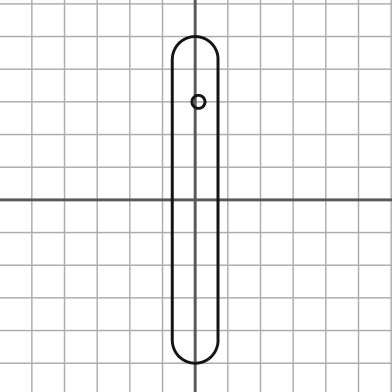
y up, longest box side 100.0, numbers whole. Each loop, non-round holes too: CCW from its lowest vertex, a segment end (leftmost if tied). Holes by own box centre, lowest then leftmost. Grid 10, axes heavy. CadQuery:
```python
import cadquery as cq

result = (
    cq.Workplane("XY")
    .moveTo(-7.0, -43.0)
    .threePointArc((0.0, -50.0), (7.0, -43.0))
    .lineTo(7.0, 43.0)
    .threePointArc((0.0, 50.0), (-7.0, 43.0))
    .close()
    .moveTo(1.0, 30.0)
    .circle(2.0)
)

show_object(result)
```